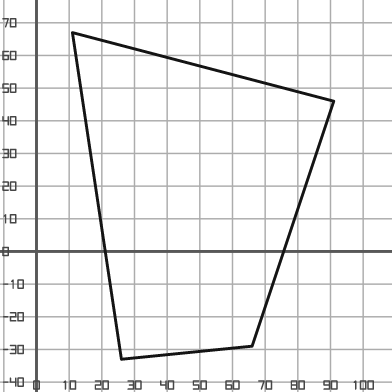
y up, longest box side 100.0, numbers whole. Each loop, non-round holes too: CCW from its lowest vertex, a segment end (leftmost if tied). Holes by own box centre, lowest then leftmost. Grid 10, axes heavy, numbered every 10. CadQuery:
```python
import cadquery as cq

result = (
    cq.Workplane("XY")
    .moveTo(26.0, -33.0)
    .lineTo(66.0, -29.0)
    .lineTo(91.0, 46.0)
    .lineTo(11.0, 67.0)
    .close()
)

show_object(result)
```